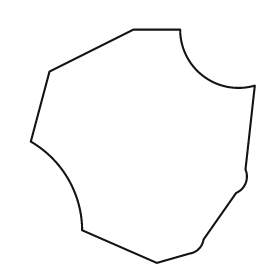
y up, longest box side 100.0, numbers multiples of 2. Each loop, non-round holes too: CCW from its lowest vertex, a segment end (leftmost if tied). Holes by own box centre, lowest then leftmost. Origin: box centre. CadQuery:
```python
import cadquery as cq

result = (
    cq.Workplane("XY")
    .moveTo(6.0, -50.0)
    .lineTo(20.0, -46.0)
    .threePointArc((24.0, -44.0), (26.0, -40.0))
    .lineTo(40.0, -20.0)
    .threePointArc((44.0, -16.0), (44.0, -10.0))
    .lineTo(48.0, 26.0)
    .threePointArc((26.0, 30.0), (16.0, 50.0))
    .lineTo(-4.0, 50.0)
    .lineTo(-40.0, 32.0)
    .lineTo(-48.0, 2.0)
    .threePointArc((-32.0, -14.0), (-26.0, -36.0))
    .close()
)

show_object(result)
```